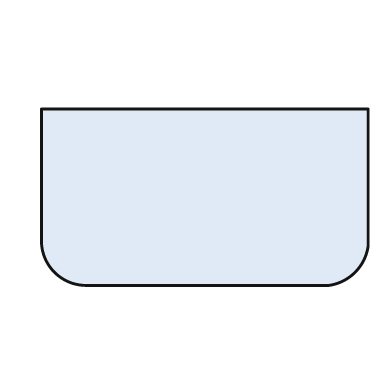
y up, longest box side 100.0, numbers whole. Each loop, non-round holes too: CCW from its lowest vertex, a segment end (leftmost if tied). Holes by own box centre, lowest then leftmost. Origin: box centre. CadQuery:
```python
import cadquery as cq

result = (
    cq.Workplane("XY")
    .moveTo(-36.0, -27.0)
    .lineTo(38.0, -27.0)
    .threePointArc((46.0, -23.0), (50.0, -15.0))
    .lineTo(50.0, 27.0)
    .lineTo(-50.0, 27.0)
    .lineTo(-50.0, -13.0)
    .threePointArc((-46.0, -23.0), (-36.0, -27.0))
    .close()
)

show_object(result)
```